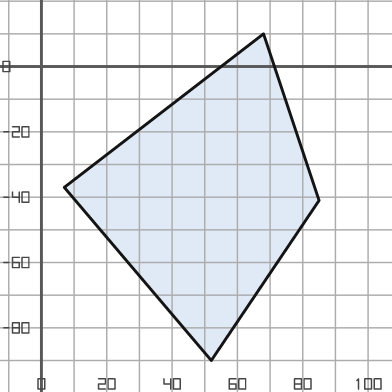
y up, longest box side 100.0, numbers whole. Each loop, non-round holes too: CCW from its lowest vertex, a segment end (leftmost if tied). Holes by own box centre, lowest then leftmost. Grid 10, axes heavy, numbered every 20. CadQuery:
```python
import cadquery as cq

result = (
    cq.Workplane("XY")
    .moveTo(52.0, -90.0)
    .lineTo(85.0, -41.0)
    .lineTo(68.0, 10.0)
    .lineTo(7.0, -37.0)
    .close()
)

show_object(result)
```